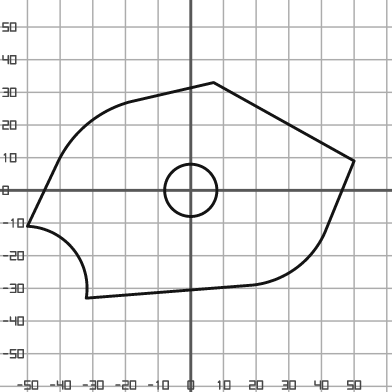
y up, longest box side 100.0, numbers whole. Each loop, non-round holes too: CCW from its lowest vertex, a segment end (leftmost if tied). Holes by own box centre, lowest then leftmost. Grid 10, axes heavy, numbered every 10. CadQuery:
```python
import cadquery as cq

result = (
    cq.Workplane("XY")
    .moveTo(-32.0, -33.0)
    .lineTo(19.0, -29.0)
    .threePointArc((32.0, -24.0), (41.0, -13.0))
    .lineTo(50.0, 9.0)
    .lineTo(7.0, 33.0)
    .lineTo(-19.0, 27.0)
    .threePointArc((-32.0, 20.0), (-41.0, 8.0))
    .lineTo(-50.0, -11.0)
    .threePointArc((-36.0, -18.0), (-32.0, -33.0))
    .close()
    .moveTo(0.0, 0.0)
    .circle(8.0)
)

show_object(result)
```